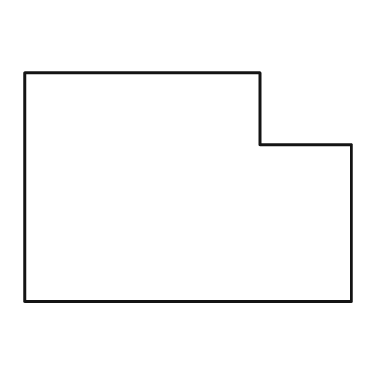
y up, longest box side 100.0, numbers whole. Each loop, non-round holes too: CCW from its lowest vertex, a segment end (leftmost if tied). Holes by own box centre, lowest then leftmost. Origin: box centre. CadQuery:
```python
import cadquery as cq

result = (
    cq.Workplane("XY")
    .moveTo(-50.0, -35.0)
    .lineTo(50.0, -35.0)
    .lineTo(50.0, 13.0)
    .lineTo(22.0, 13.0)
    .lineTo(22.0, 35.0)
    .lineTo(-50.0, 35.0)
    .close()
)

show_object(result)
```